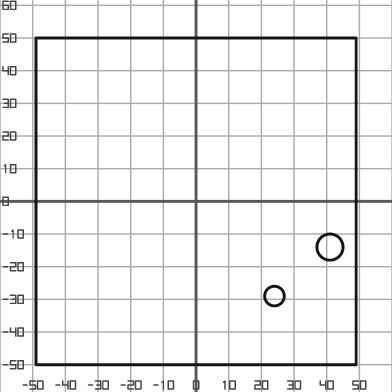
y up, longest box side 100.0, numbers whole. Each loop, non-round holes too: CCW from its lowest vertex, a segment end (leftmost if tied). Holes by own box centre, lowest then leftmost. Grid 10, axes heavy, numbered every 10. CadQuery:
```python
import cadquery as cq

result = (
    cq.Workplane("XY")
    .moveTo(-49.0, -50.0)
    .lineTo(49.0, -50.0)
    .lineTo(49.0, 50.0)
    .lineTo(-49.0, 50.0)
    .close()
    .moveTo(24.0, -29.0)
    .circle(3.0)
    .moveTo(41.0, -14.0)
    .circle(4.0)
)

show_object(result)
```